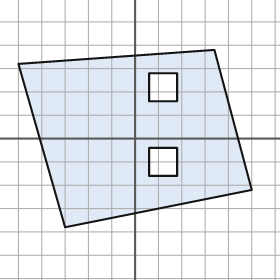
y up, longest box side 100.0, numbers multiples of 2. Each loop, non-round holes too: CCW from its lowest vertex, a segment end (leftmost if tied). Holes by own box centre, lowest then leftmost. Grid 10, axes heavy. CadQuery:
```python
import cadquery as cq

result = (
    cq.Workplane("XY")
    .moveTo(-30.0, -38.0)
    .lineTo(50.0, -22.0)
    .lineTo(34.0, 38.0)
    .lineTo(-50.0, 32.0)
    .close()
    .moveTo(6.0, -16.0)
    .lineTo(18.0, -16.0)
    .lineTo(18.0, -4.0)
    .lineTo(6.0, -4.0)
    .close()
    .moveTo(6.0, 16.0)
    .lineTo(18.0, 16.0)
    .lineTo(18.0, 28.0)
    .lineTo(6.0, 28.0)
    .close()
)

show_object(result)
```